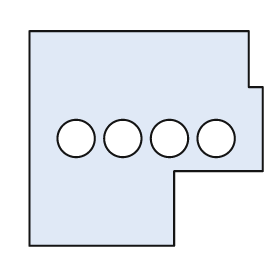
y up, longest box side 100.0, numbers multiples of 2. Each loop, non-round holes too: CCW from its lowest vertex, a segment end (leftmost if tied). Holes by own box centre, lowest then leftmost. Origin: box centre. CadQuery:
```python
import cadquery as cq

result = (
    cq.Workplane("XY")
    .moveTo(-50.0, -46.0)
    .lineTo(12.0, -46.0)
    .lineTo(12.0, -14.0)
    .lineTo(50.0, -14.0)
    .lineTo(50.0, 22.0)
    .lineTo(44.0, 22.0)
    .lineTo(44.0, 46.0)
    .lineTo(-50.0, 46.0)
    .close()
    .moveTo(-30.0, 0.0)
    .circle(8.0)
    .moveTo(-10.0, 0.0)
    .circle(8.0)
    .moveTo(10.0, 0.0)
    .circle(8.0)
    .moveTo(30.0, 0.0)
    .circle(8.0)
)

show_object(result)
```